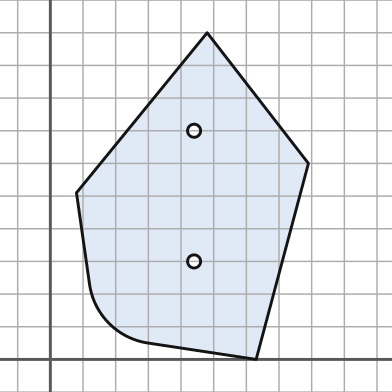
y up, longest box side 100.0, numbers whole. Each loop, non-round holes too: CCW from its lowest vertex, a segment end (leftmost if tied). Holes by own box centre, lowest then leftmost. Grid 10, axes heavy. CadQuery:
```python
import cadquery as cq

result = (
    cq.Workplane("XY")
    .moveTo(63.0, 0.0)
    .lineTo(79.0, 60.0)
    .lineTo(48.0, 100.0)
    .lineTo(8.0, 51.0)
    .lineTo(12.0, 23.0)
    .threePointArc((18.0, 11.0), (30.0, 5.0))
    .close()
    .moveTo(44.0, 30.0)
    .circle(2.0)
    .moveTo(44.0, 70.0)
    .circle(2.0)
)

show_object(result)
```